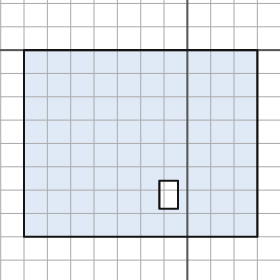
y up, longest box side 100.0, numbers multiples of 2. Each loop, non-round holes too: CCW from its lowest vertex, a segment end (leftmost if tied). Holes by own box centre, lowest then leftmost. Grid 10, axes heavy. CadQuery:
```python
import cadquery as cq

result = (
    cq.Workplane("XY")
    .moveTo(-70.0, -80.0)
    .lineTo(30.0, -80.0)
    .lineTo(30.0, 0.0)
    .lineTo(-70.0, 0.0)
    .close()
    .moveTo(-12.0, -68.0)
    .lineTo(-4.0, -68.0)
    .lineTo(-4.0, -56.0)
    .lineTo(-12.0, -56.0)
    .close()
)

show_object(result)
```